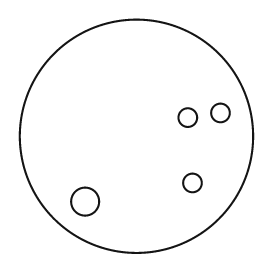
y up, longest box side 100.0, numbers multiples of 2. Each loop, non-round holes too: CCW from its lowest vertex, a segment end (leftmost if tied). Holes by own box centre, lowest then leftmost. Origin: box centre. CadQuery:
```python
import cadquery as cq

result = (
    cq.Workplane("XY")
    .moveTo(0.0, 0.0)
    .circle(50.0)
    .moveTo(-22.0, -28.0)
    .circle(6.0)
    .moveTo(24.0, -20.0)
    .circle(4.0)
    .moveTo(22.0, 8.0)
    .circle(4.0)
    .moveTo(36.0, 10.0)
    .circle(4.0)
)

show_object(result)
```